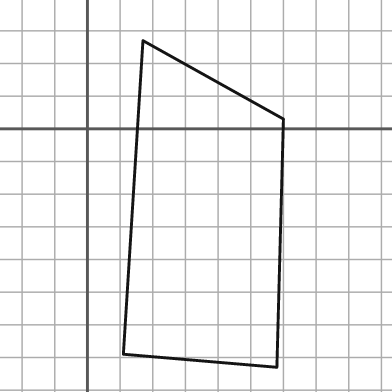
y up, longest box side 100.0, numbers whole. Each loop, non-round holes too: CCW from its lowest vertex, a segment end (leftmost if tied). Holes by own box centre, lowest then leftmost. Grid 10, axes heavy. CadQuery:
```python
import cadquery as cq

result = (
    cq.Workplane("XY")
    .moveTo(58.0, -73.0)
    .lineTo(60.0, 3.0)
    .lineTo(17.0, 27.0)
    .lineTo(11.0, -69.0)
    .close()
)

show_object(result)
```